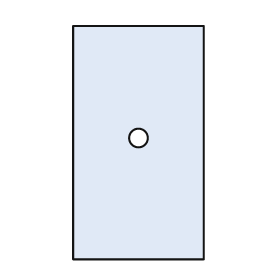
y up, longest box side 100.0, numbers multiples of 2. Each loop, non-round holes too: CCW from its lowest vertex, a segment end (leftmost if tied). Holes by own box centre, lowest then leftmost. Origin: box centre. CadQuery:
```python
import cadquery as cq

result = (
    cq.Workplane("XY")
    .moveTo(-28.0, -50.0)
    .lineTo(28.0, -50.0)
    .lineTo(28.0, 50.0)
    .lineTo(-28.0, 50.0)
    .close()
    .moveTo(0.0, 2.0)
    .circle(4.0)
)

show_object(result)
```